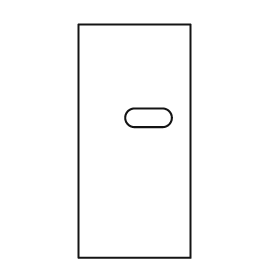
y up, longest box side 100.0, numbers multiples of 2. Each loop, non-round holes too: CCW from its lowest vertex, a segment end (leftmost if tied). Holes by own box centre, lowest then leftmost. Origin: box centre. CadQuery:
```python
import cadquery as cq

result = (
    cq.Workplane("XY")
    .moveTo(-24.0, -50.0)
    .lineTo(24.0, -50.0)
    .lineTo(24.0, 50.0)
    .lineTo(-24.0, 50.0)
    .close()
    .moveTo(0.0, 6.0)
    .lineTo(12.0, 6.0)
    .threePointArc((16.0, 10.0), (12.0, 14.0))
    .lineTo(0.0, 14.0)
    .threePointArc((-4.0, 10.0), (0.0, 6.0))
    .close()
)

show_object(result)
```